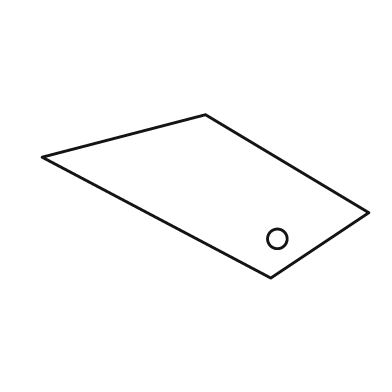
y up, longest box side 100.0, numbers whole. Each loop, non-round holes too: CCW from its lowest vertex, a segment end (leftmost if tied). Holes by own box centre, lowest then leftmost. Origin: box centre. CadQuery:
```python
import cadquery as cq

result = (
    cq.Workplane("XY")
    .moveTo(20.0, -25.0)
    .lineTo(50.0, -5.0)
    .lineTo(0.0, 25.0)
    .lineTo(-50.0, 12.0)
    .close()
    .moveTo(22.0, -13.0)
    .circle(3.0)
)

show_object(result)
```